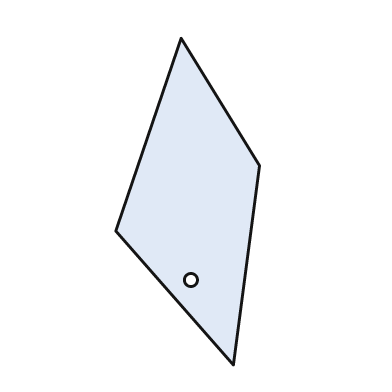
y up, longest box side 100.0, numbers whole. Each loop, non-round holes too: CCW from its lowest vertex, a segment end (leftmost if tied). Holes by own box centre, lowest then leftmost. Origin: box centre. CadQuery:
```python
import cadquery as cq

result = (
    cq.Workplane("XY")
    .moveTo(14.0, -50.0)
    .lineTo(22.0, 11.0)
    .lineTo(-2.0, 50.0)
    .lineTo(-22.0, -9.0)
    .close()
    .moveTo(1.0, -24.0)
    .circle(2.0)
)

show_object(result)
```